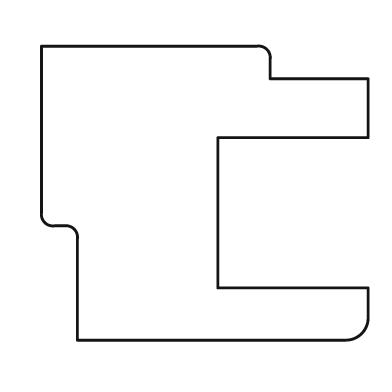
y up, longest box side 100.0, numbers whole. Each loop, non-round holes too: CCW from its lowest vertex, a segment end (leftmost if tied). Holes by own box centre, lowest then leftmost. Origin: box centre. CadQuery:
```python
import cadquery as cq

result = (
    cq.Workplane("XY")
    .moveTo(-39.0, -45.0)
    .lineTo(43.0, -45.0)
    .threePointArc((48.0, -43.0), (50.0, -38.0))
    .lineTo(50.0, -29.0)
    .lineTo(4.0, -29.0)
    .lineTo(4.0, 17.0)
    .lineTo(50.0, 17.0)
    .lineTo(50.0, 35.0)
    .lineTo(20.0, 35.0)
    .lineTo(20.0, 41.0)
    .threePointArc((19.0, 44.0), (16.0, 45.0))
    .lineTo(-50.0, 45.0)
    .lineTo(-50.0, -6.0)
    .threePointArc((-49.0, -9.0), (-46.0, -10.0))
    .lineTo(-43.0, -10.0)
    .threePointArc((-40.0, -11.0), (-39.0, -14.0))
    .close()
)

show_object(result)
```